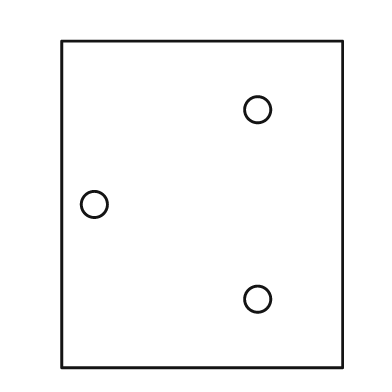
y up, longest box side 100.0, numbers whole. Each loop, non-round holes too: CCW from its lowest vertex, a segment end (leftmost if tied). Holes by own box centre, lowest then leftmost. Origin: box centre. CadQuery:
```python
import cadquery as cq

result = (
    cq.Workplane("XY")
    .moveTo(-43.0, -50.0)
    .lineTo(43.0, -50.0)
    .lineTo(43.0, 50.0)
    .lineTo(-43.0, 50.0)
    .close()
    .moveTo(17.0, -29.0)
    .circle(4.0)
    .moveTo(-33.0, 0.0)
    .circle(4.0)
    .moveTo(17.0, 29.0)
    .circle(4.0)
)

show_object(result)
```